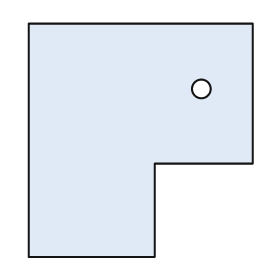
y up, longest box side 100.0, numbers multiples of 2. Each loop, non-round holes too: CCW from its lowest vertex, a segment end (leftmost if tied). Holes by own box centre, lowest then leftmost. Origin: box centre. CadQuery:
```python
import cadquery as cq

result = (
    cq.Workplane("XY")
    .moveTo(-48.0, -50.0)
    .lineTo(6.0, -50.0)
    .lineTo(6.0, -10.0)
    .lineTo(48.0, -10.0)
    .lineTo(48.0, 50.0)
    .lineTo(-48.0, 50.0)
    .close()
    .moveTo(26.0, 22.0)
    .circle(4.0)
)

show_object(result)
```